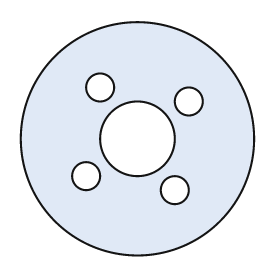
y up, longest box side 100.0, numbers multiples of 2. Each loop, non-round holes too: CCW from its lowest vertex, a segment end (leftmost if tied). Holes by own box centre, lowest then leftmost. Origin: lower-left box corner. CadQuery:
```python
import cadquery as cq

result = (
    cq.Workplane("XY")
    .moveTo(50.0, 50.0)
    .circle(50.0)
    .moveTo(66.0, 28.0)
    .circle(6.0)
    .moveTo(28.0, 34.0)
    .circle(6.0)
    .moveTo(50.0, 50.0)
    .circle(16.0)
    .moveTo(72.0, 66.0)
    .circle(6.0)
    .moveTo(34.0, 72.0)
    .circle(6.0)
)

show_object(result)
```